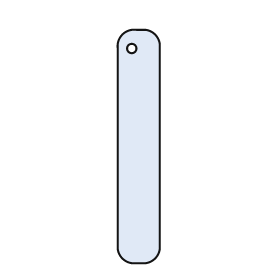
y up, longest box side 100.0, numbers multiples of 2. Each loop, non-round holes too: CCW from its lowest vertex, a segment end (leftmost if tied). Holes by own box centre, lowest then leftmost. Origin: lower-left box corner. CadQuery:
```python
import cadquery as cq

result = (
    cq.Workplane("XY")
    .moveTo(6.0, 0.0)
    .lineTo(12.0, 0.0)
    .threePointArc((16.0, 2.0), (18.0, 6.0))
    .lineTo(18.0, 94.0)
    .threePointArc((16.0, 98.0), (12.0, 100.0))
    .lineTo(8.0, 100.0)
    .threePointArc((2.0, 98.0), (0.0, 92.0))
    .lineTo(0.0, 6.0)
    .threePointArc((2.0, 2.0), (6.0, 0.0))
    .close()
    .moveTo(6.0, 92.0)
    .circle(2.0)
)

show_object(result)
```